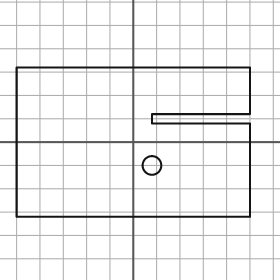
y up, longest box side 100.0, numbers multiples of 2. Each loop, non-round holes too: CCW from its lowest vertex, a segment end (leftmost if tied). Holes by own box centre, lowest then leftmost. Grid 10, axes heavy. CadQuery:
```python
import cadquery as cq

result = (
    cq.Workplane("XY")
    .moveTo(-50.0, -32.0)
    .lineTo(50.0, -32.0)
    .lineTo(50.0, 8.0)
    .lineTo(8.0, 8.0)
    .lineTo(8.0, 12.0)
    .lineTo(50.0, 12.0)
    .lineTo(50.0, 32.0)
    .lineTo(-50.0, 32.0)
    .close()
    .moveTo(8.0, -10.0)
    .circle(4.0)
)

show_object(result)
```